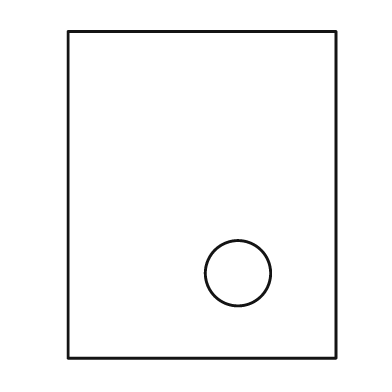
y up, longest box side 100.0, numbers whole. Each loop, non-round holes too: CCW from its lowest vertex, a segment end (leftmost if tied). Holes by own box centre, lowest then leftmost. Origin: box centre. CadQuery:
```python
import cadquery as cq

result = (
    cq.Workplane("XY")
    .moveTo(-41.0, -50.0)
    .lineTo(41.0, -50.0)
    .lineTo(41.0, 50.0)
    .lineTo(-41.0, 50.0)
    .close()
    .moveTo(11.0, -24.0)
    .circle(10.0)
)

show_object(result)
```